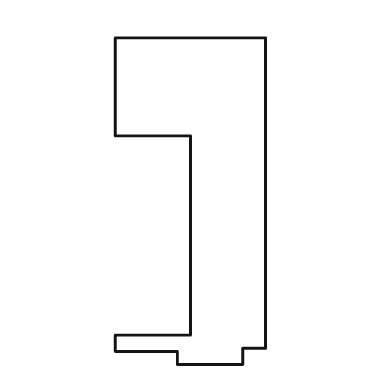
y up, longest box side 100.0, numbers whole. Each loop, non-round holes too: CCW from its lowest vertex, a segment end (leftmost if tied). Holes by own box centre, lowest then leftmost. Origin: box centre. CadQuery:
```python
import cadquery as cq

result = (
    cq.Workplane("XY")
    .moveTo(-4.0, -50.0)
    .lineTo(16.0, -50.0)
    .lineTo(16.0, -45.0)
    .lineTo(23.0, -45.0)
    .lineTo(23.0, 50.0)
    .lineTo(-23.0, 50.0)
    .lineTo(-23.0, 20.0)
    .lineTo(0.0, 20.0)
    .lineTo(0.0, -41.0)
    .lineTo(-23.0, -41.0)
    .lineTo(-23.0, -46.0)
    .lineTo(-4.0, -46.0)
    .close()
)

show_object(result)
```